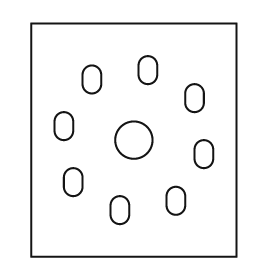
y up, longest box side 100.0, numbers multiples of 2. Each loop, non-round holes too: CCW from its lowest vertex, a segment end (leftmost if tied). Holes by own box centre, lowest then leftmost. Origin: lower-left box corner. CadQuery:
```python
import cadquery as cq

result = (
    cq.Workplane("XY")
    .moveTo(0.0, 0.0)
    .lineTo(88.0, 0.0)
    .lineTo(88.0, 100.0)
    .lineTo(0.0, 100.0)
    .close()
    .moveTo(34.0, 18.0)
    .threePointArc((38.0, 14.0), (42.0, 18.0))
    .lineTo(42.0, 22.0)
    .threePointArc((38.0, 26.0), (34.0, 22.0))
    .close()
    .moveTo(58.0, 22.0)
    .threePointArc((62.0, 18.0), (66.0, 22.0))
    .lineTo(66.0, 26.0)
    .threePointArc((62.0, 30.0), (58.0, 26.0))
    .close()
    .moveTo(14.0, 30.0)
    .threePointArc((18.0, 26.0), (22.0, 30.0))
    .lineTo(22.0, 34.0)
    .threePointArc((18.0, 38.0), (14.0, 34.0))
    .close()
    .moveTo(70.0, 42.0)
    .threePointArc((74.0, 38.0), (78.0, 42.0))
    .lineTo(78.0, 46.0)
    .threePointArc((74.0, 50.0), (70.0, 46.0))
    .close()
    .moveTo(44.0, 50.0)
    .circle(8.0)
    .moveTo(10.0, 54.0)
    .threePointArc((14.0, 50.0), (18.0, 54.0))
    .lineTo(18.0, 58.0)
    .threePointArc((14.0, 62.0), (10.0, 58.0))
    .close()
    .moveTo(66.0, 66.0)
    .threePointArc((70.0, 62.0), (74.0, 66.0))
    .lineTo(74.0, 70.0)
    .threePointArc((70.0, 74.0), (66.0, 70.0))
    .close()
    .moveTo(22.0, 74.0)
    .threePointArc((26.0, 70.0), (30.0, 74.0))
    .lineTo(30.0, 78.0)
    .threePointArc((26.0, 82.0), (22.0, 78.0))
    .close()
    .moveTo(46.0, 78.0)
    .threePointArc((50.0, 74.0), (54.0, 78.0))
    .lineTo(54.0, 82.0)
    .threePointArc((50.0, 86.0), (46.0, 82.0))
    .close()
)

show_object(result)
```